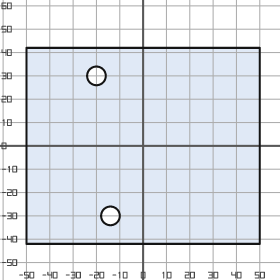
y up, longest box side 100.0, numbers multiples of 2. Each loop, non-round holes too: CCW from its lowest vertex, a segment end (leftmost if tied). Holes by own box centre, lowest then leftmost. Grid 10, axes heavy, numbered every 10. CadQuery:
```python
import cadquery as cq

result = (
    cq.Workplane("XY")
    .moveTo(-50.0, -42.0)
    .lineTo(50.0, -42.0)
    .lineTo(50.0, 42.0)
    .lineTo(-50.0, 42.0)
    .close()
    .moveTo(-14.0, -30.0)
    .circle(4.0)
    .moveTo(-20.0, 30.0)
    .circle(4.0)
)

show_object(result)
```